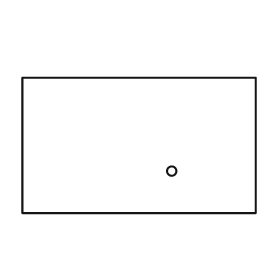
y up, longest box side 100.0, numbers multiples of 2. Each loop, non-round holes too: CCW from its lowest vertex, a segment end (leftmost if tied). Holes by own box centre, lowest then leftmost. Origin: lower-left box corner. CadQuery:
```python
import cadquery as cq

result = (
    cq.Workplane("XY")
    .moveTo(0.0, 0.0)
    .lineTo(100.0, 0.0)
    .lineTo(100.0, 58.0)
    .lineTo(0.0, 58.0)
    .close()
    .moveTo(64.0, 18.0)
    .circle(2.0)
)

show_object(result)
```